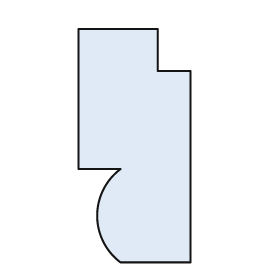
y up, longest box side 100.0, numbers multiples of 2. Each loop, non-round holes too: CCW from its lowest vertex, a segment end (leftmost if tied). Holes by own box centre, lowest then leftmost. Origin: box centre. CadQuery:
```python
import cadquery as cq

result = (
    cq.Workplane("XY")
    .moveTo(-6.0, -50.0)
    .lineTo(24.0, -50.0)
    .lineTo(24.0, 32.0)
    .lineTo(10.0, 32.0)
    .lineTo(10.0, 50.0)
    .lineTo(-24.0, 50.0)
    .lineTo(-24.0, -10.0)
    .lineTo(-6.0, -10.0)
    .threePointArc((-16.0, -30.0), (-6.0, -50.0))
    .close()
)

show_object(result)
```